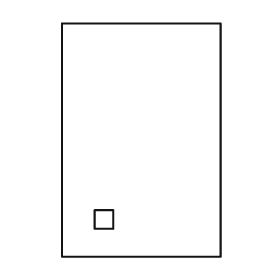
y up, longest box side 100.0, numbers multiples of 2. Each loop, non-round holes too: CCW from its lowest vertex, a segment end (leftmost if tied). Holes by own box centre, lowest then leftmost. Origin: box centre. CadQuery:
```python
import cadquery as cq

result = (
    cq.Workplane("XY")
    .moveTo(-34.0, -50.0)
    .lineTo(34.0, -50.0)
    .lineTo(34.0, 50.0)
    .lineTo(-34.0, 50.0)
    .close()
    .moveTo(-20.0, -38.0)
    .lineTo(-12.0, -38.0)
    .lineTo(-12.0, -30.0)
    .lineTo(-20.0, -30.0)
    .close()
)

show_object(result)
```